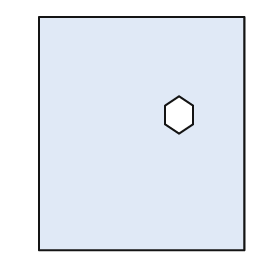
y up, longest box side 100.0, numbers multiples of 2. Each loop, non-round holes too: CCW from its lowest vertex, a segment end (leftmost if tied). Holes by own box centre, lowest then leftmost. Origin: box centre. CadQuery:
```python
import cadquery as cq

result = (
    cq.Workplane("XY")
    .moveTo(-44.0, -50.0)
    .lineTo(44.0, -50.0)
    .lineTo(44.0, 50.0)
    .lineTo(-44.0, 50.0)
    .close()
    .moveTo(16.0, 0.0)
    .lineTo(22.0, 4.0)
    .lineTo(22.0, 12.0)
    .lineTo(16.0, 16.0)
    .lineTo(10.0, 12.0)
    .lineTo(10.0, 4.0)
    .close()
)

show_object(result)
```